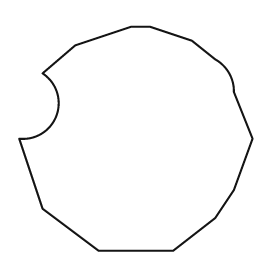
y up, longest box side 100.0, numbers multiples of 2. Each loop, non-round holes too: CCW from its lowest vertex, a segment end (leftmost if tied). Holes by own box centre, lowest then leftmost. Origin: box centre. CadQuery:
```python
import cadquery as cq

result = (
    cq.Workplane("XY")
    .moveTo(-16.0, -48.0)
    .lineTo(16.0, -48.0)
    .lineTo(34.0, -34.0)
    .lineTo(42.0, -22.0)
    .lineTo(50.0, 0.0)
    .lineTo(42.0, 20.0)
    .threePointArc((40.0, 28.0), (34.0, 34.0))
    .lineTo(24.0, 42.0)
    .lineTo(6.0, 48.0)
    .lineTo(-2.0, 48.0)
    .lineTo(-26.0, 40.0)
    .lineTo(-40.0, 28.0)
    .threePointArc((-34.0, 10.0), (-50.0, 0.0))
    .lineTo(-40.0, -30.0)
    .close()
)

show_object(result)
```